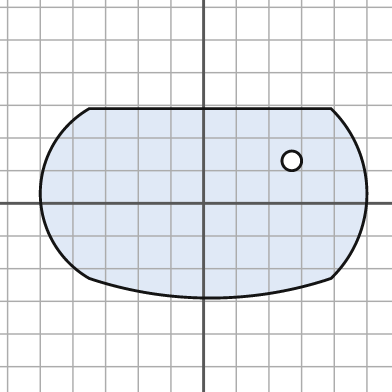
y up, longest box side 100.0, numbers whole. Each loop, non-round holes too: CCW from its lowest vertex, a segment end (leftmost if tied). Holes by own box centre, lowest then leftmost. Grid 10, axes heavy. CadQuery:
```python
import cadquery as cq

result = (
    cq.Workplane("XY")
    .moveTo(-35.0, -23.0)
    .threePointArc((2.0, -29.0), (39.0, -23.0))
    .threePointArc((50.0, 3.0), (39.0, 29.0))
    .lineTo(-35.0, 29.0)
    .threePointArc((-50.0, 3.0), (-35.0, -23.0))
    .close()
    .moveTo(27.0, 13.0)
    .circle(3.0)
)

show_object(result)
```